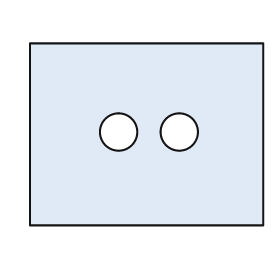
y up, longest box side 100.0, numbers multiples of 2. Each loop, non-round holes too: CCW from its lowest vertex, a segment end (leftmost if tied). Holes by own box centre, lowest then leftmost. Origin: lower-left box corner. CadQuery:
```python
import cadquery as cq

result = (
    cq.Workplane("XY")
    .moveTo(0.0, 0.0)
    .lineTo(100.0, 0.0)
    .lineTo(100.0, 78.0)
    .lineTo(0.0, 78.0)
    .close()
    .moveTo(38.0, 40.0)
    .circle(8.0)
    .moveTo(64.0, 40.0)
    .circle(8.0)
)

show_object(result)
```